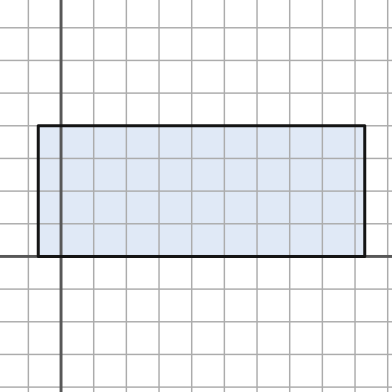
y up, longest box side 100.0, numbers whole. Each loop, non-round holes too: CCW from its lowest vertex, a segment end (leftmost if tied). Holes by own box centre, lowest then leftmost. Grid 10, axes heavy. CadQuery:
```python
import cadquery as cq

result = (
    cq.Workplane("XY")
    .moveTo(-7.0, 0.0)
    .lineTo(93.0, 0.0)
    .lineTo(93.0, 40.0)
    .lineTo(-7.0, 40.0)
    .close()
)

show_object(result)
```